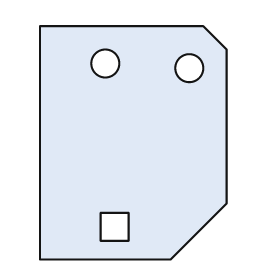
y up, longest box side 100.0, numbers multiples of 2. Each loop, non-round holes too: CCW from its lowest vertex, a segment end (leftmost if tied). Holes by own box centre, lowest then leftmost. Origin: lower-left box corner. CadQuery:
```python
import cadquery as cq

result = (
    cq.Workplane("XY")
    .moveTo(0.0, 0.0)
    .lineTo(56.0, 0.0)
    .lineTo(80.0, 24.0)
    .lineTo(80.0, 90.0)
    .lineTo(70.0, 100.0)
    .lineTo(0.0, 100.0)
    .close()
    .moveTo(26.0, 8.0)
    .lineTo(38.0, 8.0)
    .lineTo(38.0, 20.0)
    .lineTo(26.0, 20.0)
    .close()
    .moveTo(64.0, 82.0)
    .circle(6.0)
    .moveTo(28.0, 84.0)
    .circle(6.0)
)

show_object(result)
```